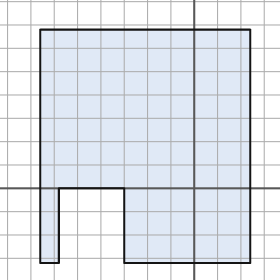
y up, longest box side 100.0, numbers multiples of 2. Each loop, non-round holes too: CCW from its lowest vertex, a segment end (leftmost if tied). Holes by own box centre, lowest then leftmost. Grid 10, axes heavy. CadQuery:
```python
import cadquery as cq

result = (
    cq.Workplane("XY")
    .moveTo(-66.0, -32.0)
    .lineTo(-58.0, -32.0)
    .lineTo(-58.0, 0.0)
    .lineTo(-30.0, 0.0)
    .lineTo(-30.0, -32.0)
    .lineTo(24.0, -32.0)
    .lineTo(24.0, 68.0)
    .lineTo(-66.0, 68.0)
    .close()
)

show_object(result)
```